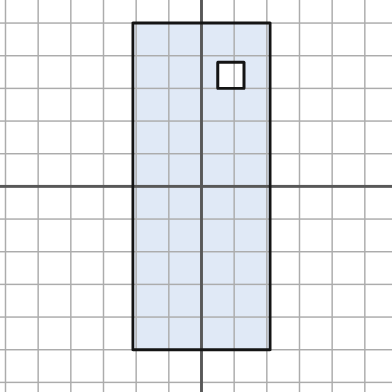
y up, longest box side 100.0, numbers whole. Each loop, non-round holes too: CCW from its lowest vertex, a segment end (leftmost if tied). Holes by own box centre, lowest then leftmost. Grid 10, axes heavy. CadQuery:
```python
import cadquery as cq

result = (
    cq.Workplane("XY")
    .moveTo(-21.0, -50.0)
    .lineTo(21.0, -50.0)
    .lineTo(21.0, 50.0)
    .lineTo(-21.0, 50.0)
    .close()
    .moveTo(5.0, 30.0)
    .lineTo(13.0, 30.0)
    .lineTo(13.0, 38.0)
    .lineTo(5.0, 38.0)
    .close()
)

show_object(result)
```